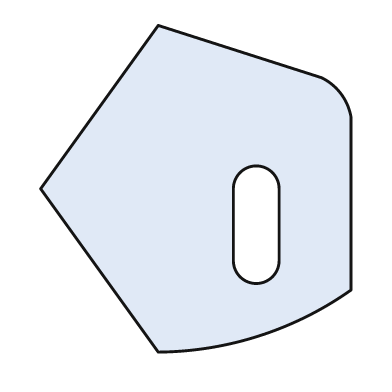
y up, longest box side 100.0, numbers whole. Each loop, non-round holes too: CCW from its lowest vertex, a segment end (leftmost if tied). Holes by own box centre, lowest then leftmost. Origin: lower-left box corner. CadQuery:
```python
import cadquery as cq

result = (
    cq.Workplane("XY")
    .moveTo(36.0, 0.0)
    .threePointArc((67.0, 5.0), (95.0, 19.0))
    .lineTo(95.0, 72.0)
    .threePointArc((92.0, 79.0), (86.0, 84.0))
    .lineTo(36.0, 100.0)
    .lineTo(0.0, 50.0)
    .close()
    .moveTo(59.0, 28.0)
    .threePointArc((66.0, 21.0), (73.0, 28.0))
    .lineTo(73.0, 50.0)
    .threePointArc((66.0, 57.0), (59.0, 50.0))
    .close()
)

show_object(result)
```